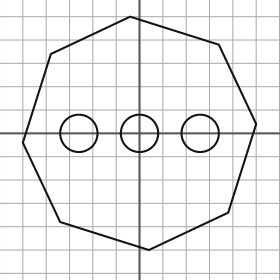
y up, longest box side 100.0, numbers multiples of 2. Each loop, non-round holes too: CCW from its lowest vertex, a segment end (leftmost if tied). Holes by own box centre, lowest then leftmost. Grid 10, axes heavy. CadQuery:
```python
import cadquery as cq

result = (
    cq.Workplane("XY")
    .moveTo(4.0, -50.0)
    .lineTo(38.0, -34.0)
    .lineTo(50.0, 4.0)
    .lineTo(34.0, 38.0)
    .lineTo(-4.0, 50.0)
    .lineTo(-38.0, 34.0)
    .lineTo(-50.0, -4.0)
    .lineTo(-34.0, -38.0)
    .close()
    .moveTo(-26.0, 0.0)
    .circle(8.0)
    .moveTo(0.0, 0.0)
    .circle(8.0)
    .moveTo(26.0, 0.0)
    .circle(8.0)
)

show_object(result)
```